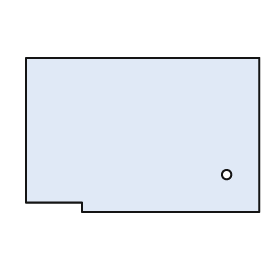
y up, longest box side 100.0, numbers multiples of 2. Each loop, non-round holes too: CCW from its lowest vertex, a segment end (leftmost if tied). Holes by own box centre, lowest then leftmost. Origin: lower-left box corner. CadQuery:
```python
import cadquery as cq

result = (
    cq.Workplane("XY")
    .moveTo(24.0, 0.0)
    .lineTo(100.0, 0.0)
    .lineTo(100.0, 66.0)
    .lineTo(0.0, 66.0)
    .lineTo(0.0, 4.0)
    .lineTo(24.0, 4.0)
    .close()
    .moveTo(86.0, 16.0)
    .circle(2.0)
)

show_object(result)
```